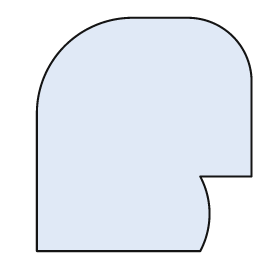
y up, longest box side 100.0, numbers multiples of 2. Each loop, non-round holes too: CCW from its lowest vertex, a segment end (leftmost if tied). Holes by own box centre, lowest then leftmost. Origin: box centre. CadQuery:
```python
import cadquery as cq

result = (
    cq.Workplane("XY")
    .moveTo(-46.0, -50.0)
    .lineTo(24.0, -50.0)
    .threePointArc((28.0, -34.0), (24.0, -18.0))
    .lineTo(46.0, -18.0)
    .lineTo(46.0, 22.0)
    .threePointArc((38.0, 42.0), (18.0, 50.0))
    .lineTo(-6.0, 50.0)
    .threePointArc((-34.0, 38.0), (-46.0, 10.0))
    .close()
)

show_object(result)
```